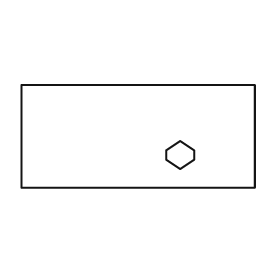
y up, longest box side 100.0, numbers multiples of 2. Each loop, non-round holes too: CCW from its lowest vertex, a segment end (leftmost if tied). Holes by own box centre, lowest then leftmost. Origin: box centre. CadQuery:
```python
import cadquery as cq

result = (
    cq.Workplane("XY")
    .moveTo(-50.0, -22.0)
    .lineTo(50.0, -22.0)
    .lineTo(50.0, 22.0)
    .lineTo(-50.0, 22.0)
    .close()
    .moveTo(18.0, -14.0)
    .lineTo(24.0, -10.0)
    .lineTo(24.0, -6.0)
    .lineTo(18.0, -2.0)
    .lineTo(12.0, -6.0)
    .lineTo(12.0, -10.0)
    .close()
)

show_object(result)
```